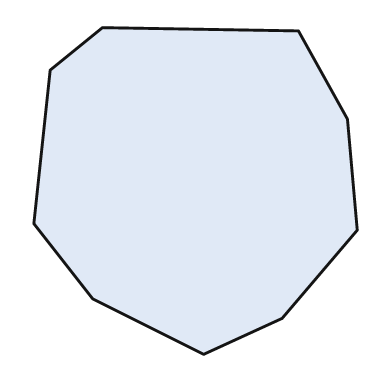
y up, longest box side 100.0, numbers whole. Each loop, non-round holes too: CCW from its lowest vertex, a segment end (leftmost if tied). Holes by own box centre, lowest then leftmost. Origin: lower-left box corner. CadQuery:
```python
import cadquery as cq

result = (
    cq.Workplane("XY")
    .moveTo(52.0, 0.0)
    .lineTo(76.0, 11.0)
    .lineTo(99.0, 38.0)
    .lineTo(96.0, 72.0)
    .lineTo(81.0, 99.0)
    .lineTo(21.0, 100.0)
    .lineTo(5.0, 87.0)
    .lineTo(0.0, 40.0)
    .lineTo(18.0, 17.0)
    .close()
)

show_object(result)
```